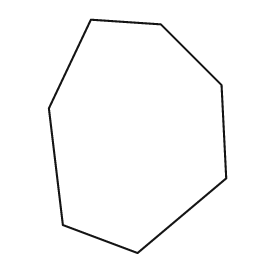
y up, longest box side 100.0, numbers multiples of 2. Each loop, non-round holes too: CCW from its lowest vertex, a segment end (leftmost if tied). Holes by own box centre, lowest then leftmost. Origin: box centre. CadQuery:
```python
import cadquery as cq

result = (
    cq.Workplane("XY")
    .moveTo(0.0, -50.0)
    .lineTo(38.0, -18.0)
    .lineTo(36.0, 22.0)
    .lineTo(10.0, 48.0)
    .lineTo(-20.0, 50.0)
    .lineTo(-38.0, 12.0)
    .lineTo(-32.0, -38.0)
    .close()
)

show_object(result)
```